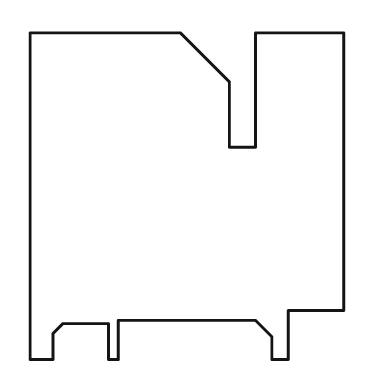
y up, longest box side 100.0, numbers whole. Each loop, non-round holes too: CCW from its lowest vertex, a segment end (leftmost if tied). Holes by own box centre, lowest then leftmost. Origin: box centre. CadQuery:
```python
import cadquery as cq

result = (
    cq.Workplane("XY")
    .moveTo(-48.0, -50.0)
    .lineTo(-41.0, -50.0)
    .lineTo(-41.0, -42.0)
    .lineTo(-38.0, -39.0)
    .lineTo(-24.0, -39.0)
    .lineTo(-24.0, -50.0)
    .lineTo(-21.0, -50.0)
    .lineTo(-21.0, -38.0)
    .lineTo(21.0, -38.0)
    .lineTo(26.0, -43.0)
    .lineTo(26.0, -50.0)
    .lineTo(31.0, -50.0)
    .lineTo(31.0, -35.0)
    .lineTo(48.0, -35.0)
    .lineTo(48.0, 50.0)
    .lineTo(21.0, 50.0)
    .lineTo(21.0, 15.0)
    .lineTo(13.0, 15.0)
    .lineTo(13.0, 35.0)
    .lineTo(-2.0, 50.0)
    .lineTo(-48.0, 50.0)
    .close()
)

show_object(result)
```